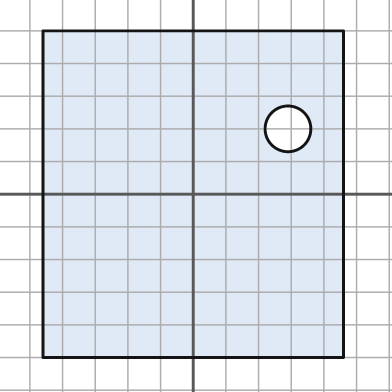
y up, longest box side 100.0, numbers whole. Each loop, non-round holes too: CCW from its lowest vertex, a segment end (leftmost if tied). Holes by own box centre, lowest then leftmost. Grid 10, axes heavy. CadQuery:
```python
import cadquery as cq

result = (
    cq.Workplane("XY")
    .moveTo(-46.0, -50.0)
    .lineTo(46.0, -50.0)
    .lineTo(46.0, 50.0)
    .lineTo(-46.0, 50.0)
    .close()
    .moveTo(29.0, 20.0)
    .circle(7.0)
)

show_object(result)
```